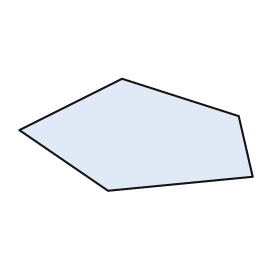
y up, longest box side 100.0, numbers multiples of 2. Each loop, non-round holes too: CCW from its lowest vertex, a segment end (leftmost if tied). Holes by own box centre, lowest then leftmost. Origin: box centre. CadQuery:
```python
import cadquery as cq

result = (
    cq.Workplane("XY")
    .moveTo(-12.0, -24.0)
    .lineTo(50.0, -18.0)
    .lineTo(44.0, 8.0)
    .lineTo(-6.0, 24.0)
    .lineTo(-50.0, 2.0)
    .close()
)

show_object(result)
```